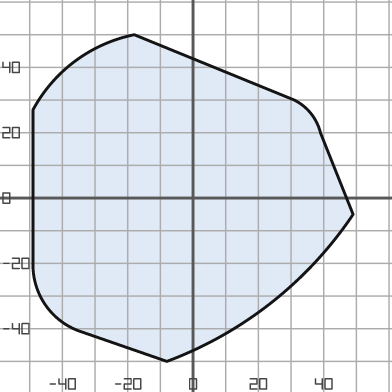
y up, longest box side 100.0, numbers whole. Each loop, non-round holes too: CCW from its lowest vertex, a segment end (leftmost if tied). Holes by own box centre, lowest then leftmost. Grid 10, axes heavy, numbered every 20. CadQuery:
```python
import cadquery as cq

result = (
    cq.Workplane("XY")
    .moveTo(-8.0, -50.0)
    .threePointArc((24.0, -32.0), (49.0, -5.0))
    .lineTo(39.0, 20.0)
    .threePointArc((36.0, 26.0), (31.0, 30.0))
    .lineTo(-18.0, 50.0)
    .threePointArc((-36.0, 42.0), (-49.0, 27.0))
    .lineTo(-49.0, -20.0)
    .threePointArc((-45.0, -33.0), (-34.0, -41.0))
    .close()
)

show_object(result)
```